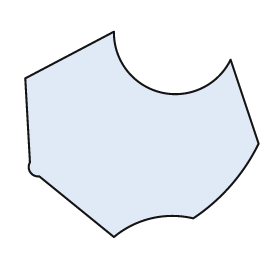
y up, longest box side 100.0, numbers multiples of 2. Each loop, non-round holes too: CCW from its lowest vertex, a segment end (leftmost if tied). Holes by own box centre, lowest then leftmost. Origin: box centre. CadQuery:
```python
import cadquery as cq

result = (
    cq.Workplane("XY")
    .moveTo(-12.0, -44.0)
    .threePointArc((4.0, -36.0), (22.0, -36.0))
    .threePointArc((38.0, -22.0), (50.0, -4.0))
    .lineTo(38.0, 32.0)
    .threePointArc((8.0, 18.0), (-12.0, 44.0))
    .lineTo(-50.0, 24.0)
    .lineTo(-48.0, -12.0)
    .threePointArc((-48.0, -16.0), (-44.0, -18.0))
    .close()
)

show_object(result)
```